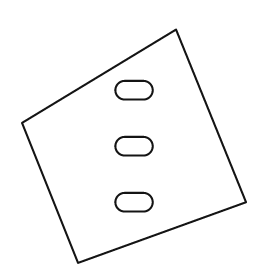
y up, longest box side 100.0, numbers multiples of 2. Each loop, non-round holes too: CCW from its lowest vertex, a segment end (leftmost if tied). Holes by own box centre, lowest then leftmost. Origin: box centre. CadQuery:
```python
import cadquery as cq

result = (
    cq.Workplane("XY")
    .moveTo(-24.0, -50.0)
    .lineTo(48.0, -24.0)
    .lineTo(18.0, 50.0)
    .lineTo(-48.0, 10.0)
    .close()
    .moveTo(-4.0, -28.0)
    .lineTo(4.0, -28.0)
    .threePointArc((8.0, -24.0), (4.0, -20.0))
    .lineTo(-4.0, -20.0)
    .threePointArc((-8.0, -24.0), (-4.0, -28.0))
    .close()
    .moveTo(-4.0, -4.0)
    .lineTo(4.0, -4.0)
    .threePointArc((8.0, 0.0), (4.0, 4.0))
    .lineTo(-4.0, 4.0)
    .threePointArc((-8.0, 0.0), (-4.0, -4.0))
    .close()
    .moveTo(-4.0, 20.0)
    .lineTo(4.0, 20.0)
    .threePointArc((8.0, 24.0), (4.0, 28.0))
    .lineTo(-4.0, 28.0)
    .threePointArc((-8.0, 24.0), (-4.0, 20.0))
    .close()
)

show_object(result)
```